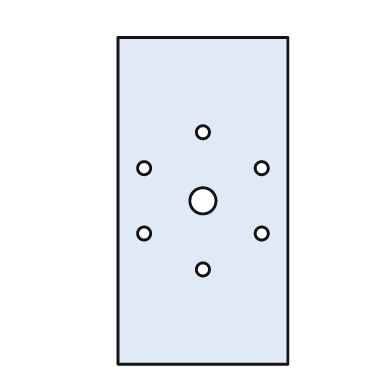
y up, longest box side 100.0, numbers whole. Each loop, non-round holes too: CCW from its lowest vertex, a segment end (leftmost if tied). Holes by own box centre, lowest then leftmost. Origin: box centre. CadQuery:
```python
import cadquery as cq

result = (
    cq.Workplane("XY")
    .moveTo(-26.0, -50.0)
    .lineTo(26.0, -50.0)
    .lineTo(26.0, 50.0)
    .lineTo(-26.0, 50.0)
    .close()
    .moveTo(0.0, -21.0)
    .circle(2.0)
    .moveTo(-18.0, -10.0)
    .circle(2.0)
    .moveTo(18.0, -10.0)
    .circle(2.0)
    .moveTo(0.0, 0.0)
    .circle(4.0)
    .moveTo(-18.0, 10.0)
    .circle(2.0)
    .moveTo(18.0, 10.0)
    .circle(2.0)
    .moveTo(0.0, 21.0)
    .circle(2.0)
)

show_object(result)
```